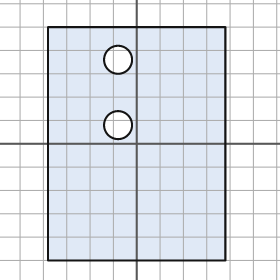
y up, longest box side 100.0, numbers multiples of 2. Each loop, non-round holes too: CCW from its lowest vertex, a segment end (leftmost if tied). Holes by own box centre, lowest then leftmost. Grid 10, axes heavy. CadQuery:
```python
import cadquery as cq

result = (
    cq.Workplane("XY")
    .moveTo(-38.0, -50.0)
    .lineTo(38.0, -50.0)
    .lineTo(38.0, 50.0)
    .lineTo(-38.0, 50.0)
    .close()
    .moveTo(-8.0, 8.0)
    .circle(6.0)
    .moveTo(-8.0, 36.0)
    .circle(6.0)
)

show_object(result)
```